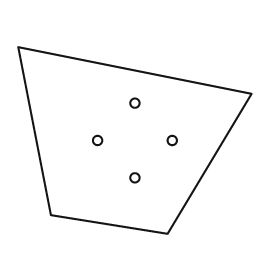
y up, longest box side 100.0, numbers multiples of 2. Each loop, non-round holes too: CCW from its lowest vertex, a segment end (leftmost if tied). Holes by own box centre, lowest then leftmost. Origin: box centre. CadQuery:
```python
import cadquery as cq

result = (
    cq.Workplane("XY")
    .moveTo(14.0, -40.0)
    .lineTo(50.0, 20.0)
    .lineTo(-50.0, 40.0)
    .lineTo(-36.0, -32.0)
    .close()
    .moveTo(0.0, -16.0)
    .circle(2.0)
    .moveTo(-16.0, 0.0)
    .circle(2.0)
    .moveTo(16.0, 0.0)
    .circle(2.0)
    .moveTo(0.0, 16.0)
    .circle(2.0)
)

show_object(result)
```